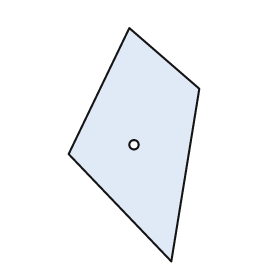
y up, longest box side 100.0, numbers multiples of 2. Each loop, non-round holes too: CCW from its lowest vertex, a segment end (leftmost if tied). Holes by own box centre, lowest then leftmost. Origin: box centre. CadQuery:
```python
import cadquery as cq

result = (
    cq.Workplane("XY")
    .moveTo(16.0, -50.0)
    .lineTo(28.0, 24.0)
    .lineTo(-2.0, 50.0)
    .lineTo(-28.0, -4.0)
    .close()
    .moveTo(0.0, 0.0)
    .circle(2.0)
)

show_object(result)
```